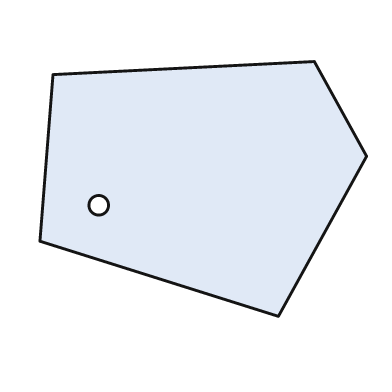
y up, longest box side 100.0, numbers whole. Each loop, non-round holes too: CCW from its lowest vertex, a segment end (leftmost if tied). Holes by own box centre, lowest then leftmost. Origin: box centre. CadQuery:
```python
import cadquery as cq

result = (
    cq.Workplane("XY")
    .moveTo(23.0, -39.0)
    .lineTo(50.0, 10.0)
    .lineTo(34.0, 39.0)
    .lineTo(-46.0, 35.0)
    .lineTo(-50.0, -16.0)
    .close()
    .moveTo(-32.0, -5.0)
    .circle(3.0)
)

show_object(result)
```